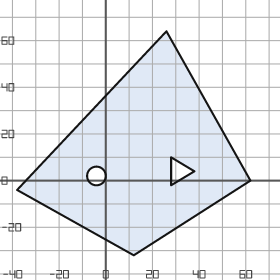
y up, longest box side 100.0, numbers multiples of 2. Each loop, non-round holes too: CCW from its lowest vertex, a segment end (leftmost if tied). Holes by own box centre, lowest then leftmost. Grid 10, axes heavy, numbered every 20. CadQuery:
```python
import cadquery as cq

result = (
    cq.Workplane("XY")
    .moveTo(12.0, -32.0)
    .lineTo(62.0, 0.0)
    .lineTo(26.0, 64.0)
    .lineTo(-38.0, -4.0)
    .close()
    .moveTo(-4.0, 2.0)
    .circle(4.0)
    .moveTo(28.0, -2.0)
    .lineTo(38.0, 4.0)
    .lineTo(28.0, 10.0)
    .close()
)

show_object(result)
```